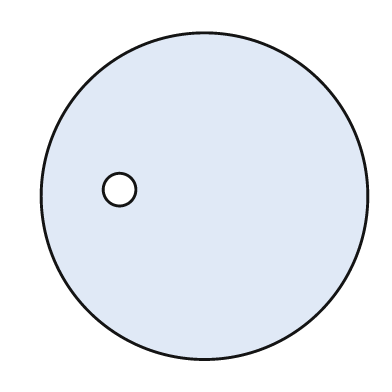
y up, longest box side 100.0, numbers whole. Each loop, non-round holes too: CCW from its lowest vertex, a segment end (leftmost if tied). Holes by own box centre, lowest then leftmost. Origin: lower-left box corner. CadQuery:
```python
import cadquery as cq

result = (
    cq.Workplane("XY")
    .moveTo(50.0, 50.0)
    .circle(50.0)
    .moveTo(24.0, 52.0)
    .circle(5.0)
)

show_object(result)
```